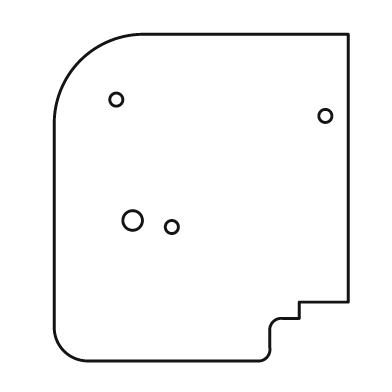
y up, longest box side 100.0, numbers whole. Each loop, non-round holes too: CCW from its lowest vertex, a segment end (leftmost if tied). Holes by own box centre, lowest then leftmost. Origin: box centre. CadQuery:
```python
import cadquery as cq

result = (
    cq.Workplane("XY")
    .moveTo(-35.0, -50.0)
    .lineTo(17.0, -50.0)
    .threePointArc((20.0, -49.0), (21.0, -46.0))
    .lineTo(21.0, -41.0)
    .threePointArc((22.0, -38.0), (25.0, -37.0))
    .lineTo(30.0, -37.0)
    .lineTo(30.0, -32.0)
    .lineTo(45.0, -32.0)
    .lineTo(45.0, 50.0)
    .lineTo(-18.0, 50.0)
    .threePointArc((-37.0, 42.0), (-45.0, 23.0))
    .lineTo(-45.0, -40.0)
    .threePointArc((-42.0, -47.0), (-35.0, -50.0))
    .close()
    .moveTo(-9.0, -9.0)
    .circle(2.0)
    .moveTo(-21.0, -7.0)
    .circle(3.0)
    .moveTo(38.0, 25.0)
    .circle(2.0)
    .moveTo(-26.0, 30.0)
    .circle(2.0)
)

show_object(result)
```